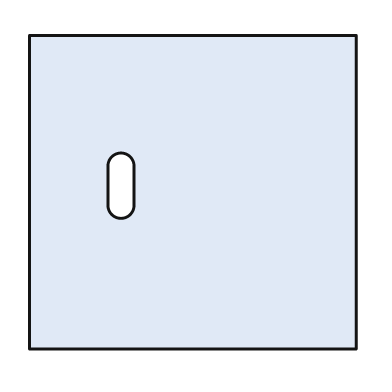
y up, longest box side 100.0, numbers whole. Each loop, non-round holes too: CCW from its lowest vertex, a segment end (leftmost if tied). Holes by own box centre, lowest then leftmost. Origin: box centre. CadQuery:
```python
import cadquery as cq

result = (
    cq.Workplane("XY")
    .moveTo(-50.0, -48.0)
    .lineTo(50.0, -48.0)
    .lineTo(50.0, 48.0)
    .lineTo(-50.0, 48.0)
    .close()
    .moveTo(-26.0, -4.0)
    .threePointArc((-22.0, -8.0), (-18.0, -4.0))
    .lineTo(-18.0, 8.0)
    .threePointArc((-22.0, 12.0), (-26.0, 8.0))
    .close()
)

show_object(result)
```